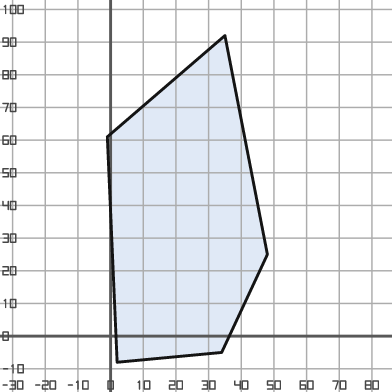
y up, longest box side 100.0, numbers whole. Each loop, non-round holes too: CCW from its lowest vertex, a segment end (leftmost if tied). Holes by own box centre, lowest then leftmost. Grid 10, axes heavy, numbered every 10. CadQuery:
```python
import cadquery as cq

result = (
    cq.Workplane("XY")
    .moveTo(2.0, -8.0)
    .lineTo(34.0, -5.0)
    .lineTo(48.0, 25.0)
    .lineTo(35.0, 92.0)
    .lineTo(-1.0, 61.0)
    .close()
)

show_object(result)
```